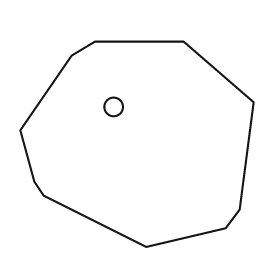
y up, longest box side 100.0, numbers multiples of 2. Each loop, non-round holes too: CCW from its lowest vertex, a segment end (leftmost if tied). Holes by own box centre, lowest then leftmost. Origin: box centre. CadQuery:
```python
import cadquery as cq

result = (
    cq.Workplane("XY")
    .moveTo(4.0, -44.0)
    .lineTo(38.0, -36.0)
    .lineTo(44.0, -28.0)
    .lineTo(50.0, 18.0)
    .lineTo(20.0, 44.0)
    .lineTo(-18.0, 44.0)
    .lineTo(-28.0, 38.0)
    .lineTo(-50.0, 6.0)
    .lineTo(-44.0, -16.0)
    .lineTo(-40.0, -22.0)
    .close()
    .moveTo(-10.0, 16.0)
    .circle(4.0)
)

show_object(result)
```